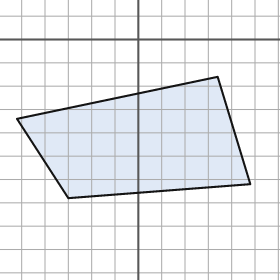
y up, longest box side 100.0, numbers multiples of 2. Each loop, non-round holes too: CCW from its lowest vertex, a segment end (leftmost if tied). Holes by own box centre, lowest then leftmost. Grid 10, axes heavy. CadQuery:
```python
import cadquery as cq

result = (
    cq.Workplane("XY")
    .moveTo(-30.0, -68.0)
    .lineTo(48.0, -62.0)
    .lineTo(34.0, -16.0)
    .lineTo(-52.0, -34.0)
    .close()
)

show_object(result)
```